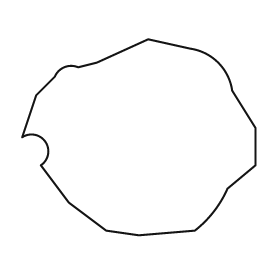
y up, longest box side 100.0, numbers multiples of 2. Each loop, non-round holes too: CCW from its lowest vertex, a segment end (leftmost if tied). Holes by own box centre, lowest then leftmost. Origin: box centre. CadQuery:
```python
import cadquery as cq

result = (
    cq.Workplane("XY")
    .moveTo(0.0, -42.0)
    .lineTo(24.0, -40.0)
    .threePointArc((32.0, -32.0), (38.0, -22.0))
    .lineTo(50.0, -12.0)
    .lineTo(50.0, 4.0)
    .lineTo(40.0, 20.0)
    .threePointArc((34.0, 32.0), (22.0, 38.0))
    .lineTo(4.0, 42.0)
    .lineTo(-18.0, 32.0)
    .lineTo(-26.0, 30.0)
    .threePointArc((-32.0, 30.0), (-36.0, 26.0))
    .lineTo(-44.0, 18.0)
    .lineTo(-50.0, 0.0)
    .threePointArc((-40.0, -2.0), (-42.0, -12.0))
    .lineTo(-30.0, -28.0)
    .lineTo(-14.0, -40.0)
    .close()
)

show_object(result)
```